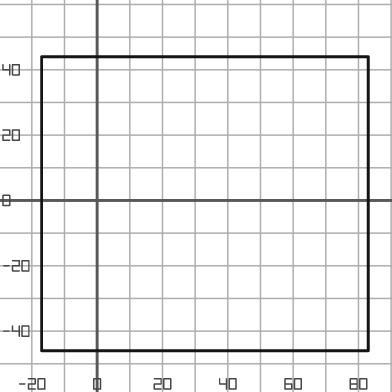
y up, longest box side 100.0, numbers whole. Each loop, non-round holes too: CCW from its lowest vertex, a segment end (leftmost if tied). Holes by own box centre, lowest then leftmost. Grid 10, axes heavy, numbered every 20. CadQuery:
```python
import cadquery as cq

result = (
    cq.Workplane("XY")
    .moveTo(-17.0, -46.0)
    .lineTo(83.0, -46.0)
    .lineTo(83.0, 44.0)
    .lineTo(-17.0, 44.0)
    .close()
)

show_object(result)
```